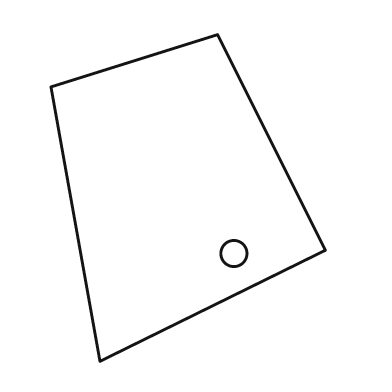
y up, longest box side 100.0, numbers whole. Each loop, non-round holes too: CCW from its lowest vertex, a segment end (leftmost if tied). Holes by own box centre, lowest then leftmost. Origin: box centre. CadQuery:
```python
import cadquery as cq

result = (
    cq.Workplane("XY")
    .moveTo(-27.0, -50.0)
    .lineTo(42.0, -16.0)
    .lineTo(9.0, 50.0)
    .lineTo(-42.0, 34.0)
    .close()
    .moveTo(14.0, -17.0)
    .circle(4.0)
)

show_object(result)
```